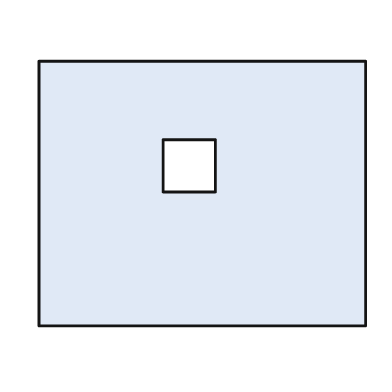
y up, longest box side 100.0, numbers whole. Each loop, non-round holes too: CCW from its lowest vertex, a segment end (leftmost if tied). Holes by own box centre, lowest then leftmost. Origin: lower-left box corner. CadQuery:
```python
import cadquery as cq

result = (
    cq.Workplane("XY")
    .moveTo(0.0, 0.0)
    .lineTo(100.0, 0.0)
    .lineTo(100.0, 81.0)
    .lineTo(0.0, 81.0)
    .close()
    .moveTo(38.0, 41.0)
    .lineTo(54.0, 41.0)
    .lineTo(54.0, 57.0)
    .lineTo(38.0, 57.0)
    .close()
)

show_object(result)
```